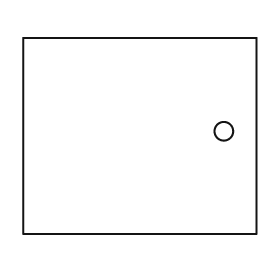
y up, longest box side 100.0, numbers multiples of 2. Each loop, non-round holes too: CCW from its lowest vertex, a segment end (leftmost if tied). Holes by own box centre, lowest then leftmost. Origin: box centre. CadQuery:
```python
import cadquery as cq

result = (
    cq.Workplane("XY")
    .moveTo(-50.0, -42.0)
    .lineTo(50.0, -42.0)
    .lineTo(50.0, 42.0)
    .lineTo(-50.0, 42.0)
    .close()
    .moveTo(36.0, 2.0)
    .circle(4.0)
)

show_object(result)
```